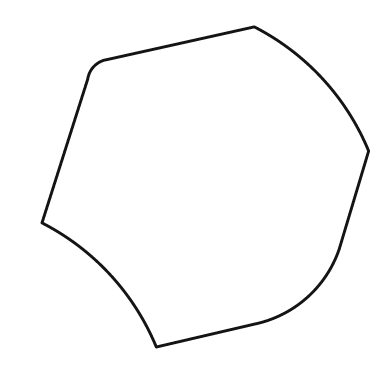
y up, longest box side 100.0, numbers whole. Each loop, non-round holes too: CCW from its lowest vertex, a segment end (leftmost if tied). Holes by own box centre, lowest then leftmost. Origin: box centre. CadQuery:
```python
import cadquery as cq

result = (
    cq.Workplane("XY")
    .moveTo(-15.0, -49.0)
    .lineTo(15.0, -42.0)
    .threePointArc((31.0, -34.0), (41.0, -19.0))
    .lineTo(50.0, 11.0)
    .threePointArc((36.0, 33.0), (15.0, 49.0))
    .lineTo(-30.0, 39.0)
    .threePointArc((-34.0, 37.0), (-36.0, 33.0))
    .lineTo(-50.0, -11.0)
    .threePointArc((-29.0, -27.0), (-15.0, -49.0))
    .close()
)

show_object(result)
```